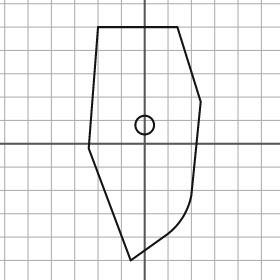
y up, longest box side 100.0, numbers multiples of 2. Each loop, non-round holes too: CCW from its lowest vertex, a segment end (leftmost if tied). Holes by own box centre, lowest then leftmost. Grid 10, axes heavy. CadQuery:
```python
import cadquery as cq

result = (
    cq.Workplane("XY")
    .moveTo(-6.0, -50.0)
    .lineTo(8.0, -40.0)
    .threePointArc((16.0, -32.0), (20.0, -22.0))
    .lineTo(24.0, 18.0)
    .lineTo(14.0, 50.0)
    .lineTo(-20.0, 50.0)
    .lineTo(-24.0, -2.0)
    .close()
    .moveTo(0.0, 8.0)
    .circle(4.0)
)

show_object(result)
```